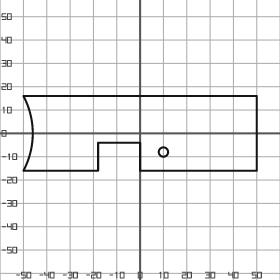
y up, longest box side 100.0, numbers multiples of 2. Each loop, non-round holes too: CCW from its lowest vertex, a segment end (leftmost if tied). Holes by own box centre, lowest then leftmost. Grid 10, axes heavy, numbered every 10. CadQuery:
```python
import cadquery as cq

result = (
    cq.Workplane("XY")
    .moveTo(-50.0, -16.0)
    .lineTo(-18.0, -16.0)
    .lineTo(-18.0, -4.0)
    .lineTo(0.0, -4.0)
    .lineTo(0.0, -16.0)
    .lineTo(50.0, -16.0)
    .lineTo(50.0, 16.0)
    .lineTo(-50.0, 16.0)
    .threePointArc((-46.0, 0.0), (-50.0, -16.0))
    .close()
    .moveTo(10.0, -8.0)
    .circle(2.0)
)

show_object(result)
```